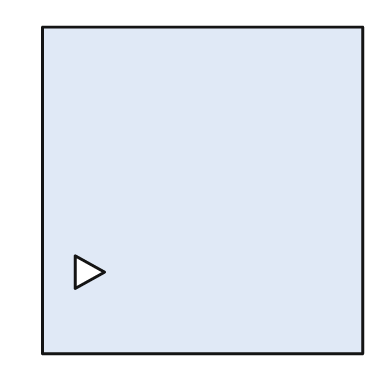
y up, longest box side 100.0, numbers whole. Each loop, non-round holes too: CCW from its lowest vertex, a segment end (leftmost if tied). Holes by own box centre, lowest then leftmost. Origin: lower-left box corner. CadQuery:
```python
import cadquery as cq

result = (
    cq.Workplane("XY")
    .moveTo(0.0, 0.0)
    .lineTo(98.0, 0.0)
    .lineTo(98.0, 100.0)
    .lineTo(0.0, 100.0)
    .close()
    .moveTo(10.0, 20.0)
    .lineTo(19.0, 25.0)
    .lineTo(10.0, 30.0)
    .close()
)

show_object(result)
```